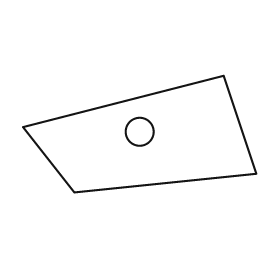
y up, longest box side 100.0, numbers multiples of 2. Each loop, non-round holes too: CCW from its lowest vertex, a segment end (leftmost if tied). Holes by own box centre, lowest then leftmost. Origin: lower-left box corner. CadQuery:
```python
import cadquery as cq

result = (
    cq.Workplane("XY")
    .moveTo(22.0, 0.0)
    .lineTo(100.0, 8.0)
    .lineTo(86.0, 50.0)
    .lineTo(0.0, 28.0)
    .close()
    .moveTo(50.0, 26.0)
    .circle(6.0)
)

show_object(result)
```